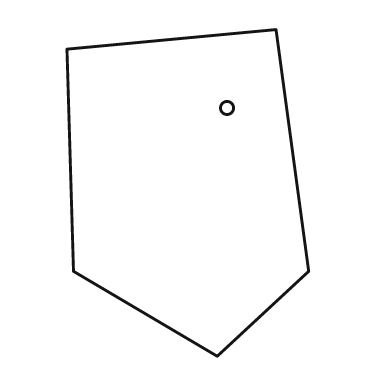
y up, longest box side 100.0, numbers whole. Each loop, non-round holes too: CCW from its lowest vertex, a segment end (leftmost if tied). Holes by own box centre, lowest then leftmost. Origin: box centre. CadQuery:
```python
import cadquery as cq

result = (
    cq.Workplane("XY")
    .moveTo(9.0, -50.0)
    .lineTo(37.0, -24.0)
    .lineTo(27.0, 50.0)
    .lineTo(-37.0, 44.0)
    .lineTo(-35.0, -24.0)
    .close()
    .moveTo(12.0, 26.0)
    .circle(2.0)
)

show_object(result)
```